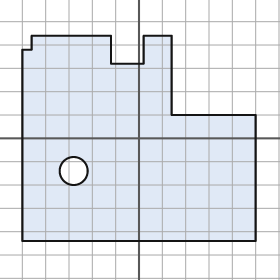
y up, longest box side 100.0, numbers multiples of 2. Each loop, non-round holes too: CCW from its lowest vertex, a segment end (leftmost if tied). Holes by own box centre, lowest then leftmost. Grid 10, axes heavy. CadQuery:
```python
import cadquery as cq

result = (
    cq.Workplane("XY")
    .moveTo(-50.0, -44.0)
    .lineTo(50.0, -44.0)
    .lineTo(50.0, 10.0)
    .lineTo(14.0, 10.0)
    .lineTo(14.0, 44.0)
    .lineTo(2.0, 44.0)
    .lineTo(2.0, 32.0)
    .lineTo(-12.0, 32.0)
    .lineTo(-12.0, 44.0)
    .lineTo(-46.0, 44.0)
    .lineTo(-46.0, 38.0)
    .lineTo(-50.0, 38.0)
    .close()
    .moveTo(-28.0, -14.0)
    .circle(6.0)
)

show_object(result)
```